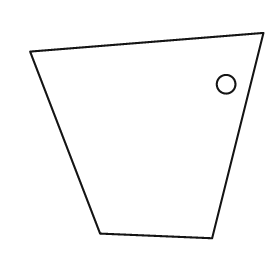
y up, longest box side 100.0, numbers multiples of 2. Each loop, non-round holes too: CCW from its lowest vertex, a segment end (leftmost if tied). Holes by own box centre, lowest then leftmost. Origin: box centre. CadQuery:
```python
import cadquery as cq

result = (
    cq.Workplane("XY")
    .moveTo(28.0, -44.0)
    .lineTo(50.0, 44.0)
    .lineTo(-50.0, 36.0)
    .lineTo(-20.0, -42.0)
    .close()
    .moveTo(34.0, 22.0)
    .circle(4.0)
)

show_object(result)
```